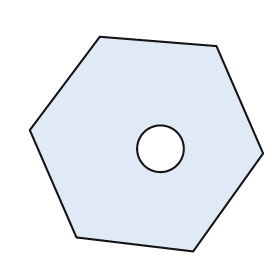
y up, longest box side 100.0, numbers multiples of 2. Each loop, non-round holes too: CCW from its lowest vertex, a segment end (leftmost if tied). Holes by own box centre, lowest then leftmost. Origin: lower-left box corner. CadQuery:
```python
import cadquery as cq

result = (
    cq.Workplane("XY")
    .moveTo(70.0, 0.0)
    .lineTo(100.0, 42.0)
    .lineTo(80.0, 88.0)
    .lineTo(30.0, 92.0)
    .lineTo(0.0, 52.0)
    .lineTo(20.0, 6.0)
    .close()
    .moveTo(56.0, 44.0)
    .circle(10.0)
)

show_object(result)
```